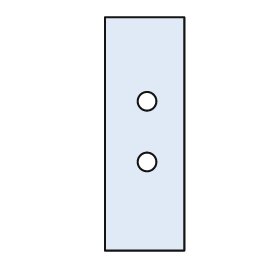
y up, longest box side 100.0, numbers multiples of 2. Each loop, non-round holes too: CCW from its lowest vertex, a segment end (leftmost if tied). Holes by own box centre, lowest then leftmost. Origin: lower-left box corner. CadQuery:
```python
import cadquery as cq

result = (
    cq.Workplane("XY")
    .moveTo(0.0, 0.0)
    .lineTo(34.0, 0.0)
    .lineTo(34.0, 100.0)
    .lineTo(0.0, 100.0)
    .close()
    .moveTo(18.0, 38.0)
    .circle(4.0)
    .moveTo(18.0, 64.0)
    .circle(4.0)
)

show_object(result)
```